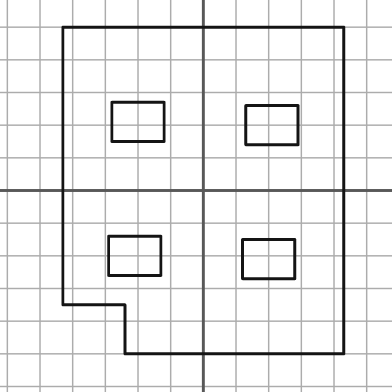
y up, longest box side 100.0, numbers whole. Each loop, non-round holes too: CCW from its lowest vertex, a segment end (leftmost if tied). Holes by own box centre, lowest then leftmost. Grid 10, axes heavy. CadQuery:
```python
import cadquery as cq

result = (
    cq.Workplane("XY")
    .moveTo(-24.0, -50.0)
    .lineTo(43.0, -50.0)
    .lineTo(43.0, 50.0)
    .lineTo(-43.0, 50.0)
    .lineTo(-43.0, -35.0)
    .lineTo(-24.0, -35.0)
    .close()
    .moveTo(12.0, -27.0)
    .lineTo(28.0, -27.0)
    .lineTo(28.0, -15.0)
    .lineTo(12.0, -15.0)
    .close()
    .moveTo(-29.0, -26.0)
    .lineTo(-13.0, -26.0)
    .lineTo(-13.0, -14.0)
    .lineTo(-29.0, -14.0)
    .close()
    .moveTo(13.0, 14.0)
    .lineTo(29.0, 14.0)
    .lineTo(29.0, 26.0)
    .lineTo(13.0, 26.0)
    .close()
    .moveTo(-28.0, 15.0)
    .lineTo(-12.0, 15.0)
    .lineTo(-12.0, 27.0)
    .lineTo(-28.0, 27.0)
    .close()
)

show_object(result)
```